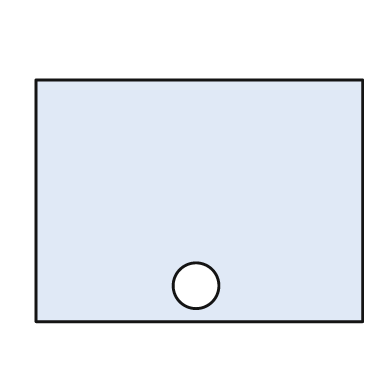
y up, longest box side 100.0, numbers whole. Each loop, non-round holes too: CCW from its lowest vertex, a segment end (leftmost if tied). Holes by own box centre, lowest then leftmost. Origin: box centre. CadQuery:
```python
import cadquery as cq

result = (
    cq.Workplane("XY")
    .moveTo(-50.0, -37.0)
    .lineTo(50.0, -37.0)
    .lineTo(50.0, 37.0)
    .lineTo(-50.0, 37.0)
    .close()
    .moveTo(-1.0, -26.0)
    .circle(7.0)
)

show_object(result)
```